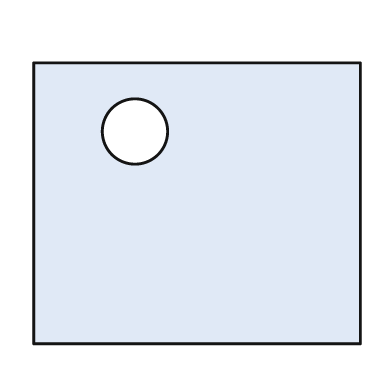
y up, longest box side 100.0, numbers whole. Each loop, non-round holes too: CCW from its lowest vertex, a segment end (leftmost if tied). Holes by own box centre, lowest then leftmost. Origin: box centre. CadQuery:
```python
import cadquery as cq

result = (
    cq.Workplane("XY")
    .moveTo(-50.0, -43.0)
    .lineTo(50.0, -43.0)
    .lineTo(50.0, 43.0)
    .lineTo(-50.0, 43.0)
    .close()
    .moveTo(-19.0, 22.0)
    .circle(10.0)
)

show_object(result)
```